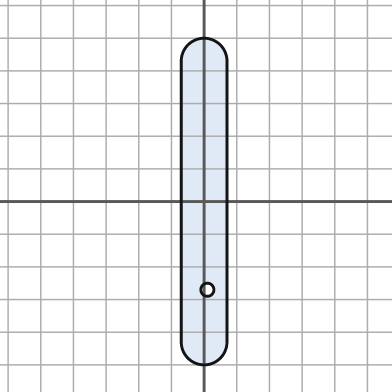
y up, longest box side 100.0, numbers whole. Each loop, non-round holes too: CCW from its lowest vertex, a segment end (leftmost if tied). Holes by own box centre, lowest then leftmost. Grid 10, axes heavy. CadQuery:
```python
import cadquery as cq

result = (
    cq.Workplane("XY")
    .moveTo(-7.0, -43.0)
    .threePointArc((0.0, -50.0), (7.0, -43.0))
    .lineTo(7.0, 43.0)
    .threePointArc((0.0, 50.0), (-7.0, 43.0))
    .close()
    .moveTo(1.0, -27.0)
    .circle(2.0)
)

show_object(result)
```